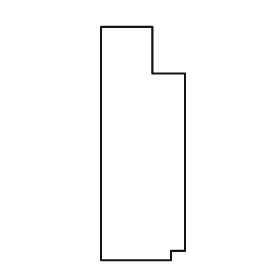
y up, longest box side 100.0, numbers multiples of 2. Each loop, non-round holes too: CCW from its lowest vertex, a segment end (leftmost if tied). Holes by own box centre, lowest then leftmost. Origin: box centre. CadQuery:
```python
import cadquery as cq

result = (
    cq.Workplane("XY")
    .moveTo(-18.0, -50.0)
    .lineTo(12.0, -50.0)
    .lineTo(12.0, -46.0)
    .lineTo(18.0, -46.0)
    .lineTo(18.0, 30.0)
    .lineTo(4.0, 30.0)
    .lineTo(4.0, 50.0)
    .lineTo(-18.0, 50.0)
    .close()
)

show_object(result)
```